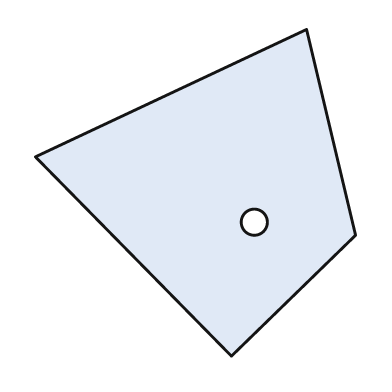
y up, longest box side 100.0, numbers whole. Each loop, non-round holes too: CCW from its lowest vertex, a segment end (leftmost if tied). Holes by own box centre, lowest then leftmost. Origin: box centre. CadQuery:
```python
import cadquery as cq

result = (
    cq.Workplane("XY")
    .moveTo(11.0, -50.0)
    .lineTo(49.0, -13.0)
    .lineTo(34.0, 50.0)
    .lineTo(-49.0, 11.0)
    .close()
    .moveTo(18.0, -9.0)
    .circle(4.0)
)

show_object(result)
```